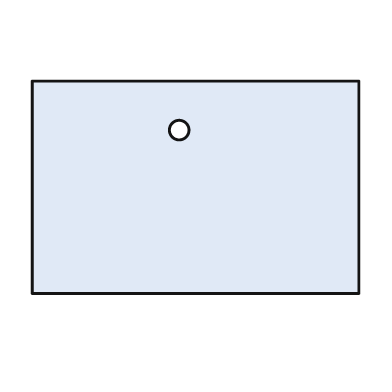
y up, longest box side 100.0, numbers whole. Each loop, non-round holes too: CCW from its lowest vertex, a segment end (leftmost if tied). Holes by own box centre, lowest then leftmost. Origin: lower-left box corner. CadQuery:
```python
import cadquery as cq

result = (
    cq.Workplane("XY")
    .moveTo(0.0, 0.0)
    .lineTo(100.0, 0.0)
    .lineTo(100.0, 65.0)
    .lineTo(0.0, 65.0)
    .close()
    .moveTo(45.0, 50.0)
    .circle(3.0)
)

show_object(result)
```